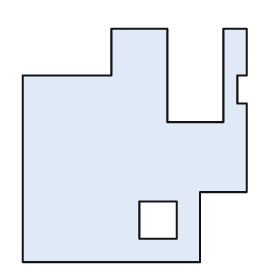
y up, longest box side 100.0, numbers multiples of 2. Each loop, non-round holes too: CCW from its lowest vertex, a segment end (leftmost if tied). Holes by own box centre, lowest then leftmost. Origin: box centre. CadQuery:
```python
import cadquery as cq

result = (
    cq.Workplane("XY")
    .moveTo(-48.0, -50.0)
    .lineTo(28.0, -50.0)
    .lineTo(28.0, -20.0)
    .lineTo(48.0, -20.0)
    .lineTo(48.0, 18.0)
    .lineTo(44.0, 18.0)
    .lineTo(44.0, 30.0)
    .lineTo(48.0, 30.0)
    .lineTo(48.0, 50.0)
    .lineTo(38.0, 50.0)
    .lineTo(38.0, 10.0)
    .lineTo(14.0, 10.0)
    .lineTo(14.0, 50.0)
    .lineTo(-10.0, 50.0)
    .lineTo(-10.0, 30.0)
    .lineTo(-48.0, 30.0)
    .close()
    .moveTo(2.0, -40.0)
    .lineTo(18.0, -40.0)
    .lineTo(18.0, -24.0)
    .lineTo(2.0, -24.0)
    .close()
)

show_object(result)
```